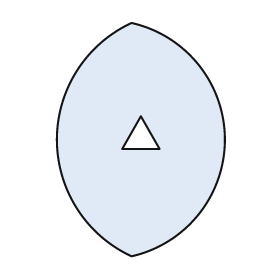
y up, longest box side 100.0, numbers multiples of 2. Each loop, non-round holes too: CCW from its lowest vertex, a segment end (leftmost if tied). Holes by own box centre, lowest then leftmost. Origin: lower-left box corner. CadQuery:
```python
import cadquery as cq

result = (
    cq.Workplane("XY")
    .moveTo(32.0, 0.0)
    .threePointArc((72.0, 50.0), (32.0, 100.0))
    .threePointArc((0.0, 50.0), (32.0, 0.0))
    .close()
    .moveTo(28.0, 46.0)
    .lineTo(44.0, 46.0)
    .lineTo(36.0, 60.0)
    .close()
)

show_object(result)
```